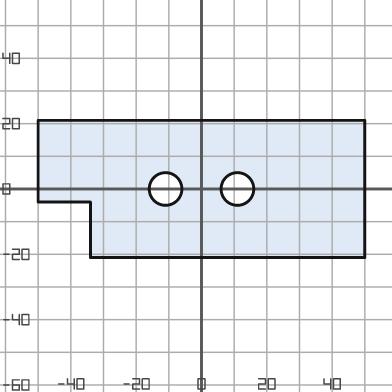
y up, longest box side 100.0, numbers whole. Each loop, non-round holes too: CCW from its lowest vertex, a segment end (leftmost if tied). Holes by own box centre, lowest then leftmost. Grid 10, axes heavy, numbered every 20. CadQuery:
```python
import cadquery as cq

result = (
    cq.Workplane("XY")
    .moveTo(-34.0, -21.0)
    .lineTo(50.0, -21.0)
    .lineTo(50.0, 21.0)
    .lineTo(-50.0, 21.0)
    .lineTo(-50.0, -4.0)
    .lineTo(-34.0, -4.0)
    .close()
    .moveTo(-11.0, 0.0)
    .circle(5.0)
    .moveTo(11.0, 0.0)
    .circle(5.0)
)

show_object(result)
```